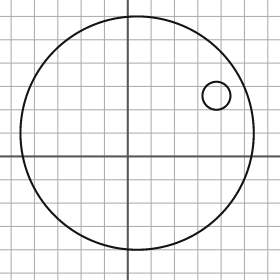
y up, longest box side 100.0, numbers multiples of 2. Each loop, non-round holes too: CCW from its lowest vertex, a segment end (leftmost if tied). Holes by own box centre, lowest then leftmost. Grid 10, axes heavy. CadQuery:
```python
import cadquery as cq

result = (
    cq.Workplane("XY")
    .moveTo(4.0, 10.0)
    .circle(50.0)
    .moveTo(38.0, 26.0)
    .circle(6.0)
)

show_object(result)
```